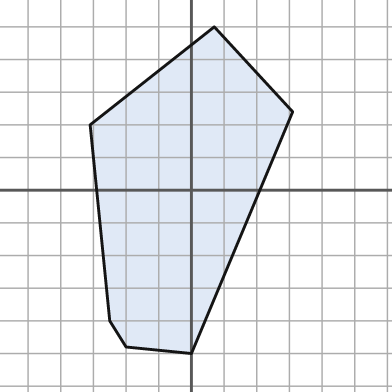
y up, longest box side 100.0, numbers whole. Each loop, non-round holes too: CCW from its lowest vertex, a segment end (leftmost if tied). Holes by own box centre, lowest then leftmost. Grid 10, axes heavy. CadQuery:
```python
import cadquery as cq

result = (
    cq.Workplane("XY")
    .moveTo(0.0, -50.0)
    .lineTo(31.0, 24.0)
    .lineTo(7.0, 50.0)
    .lineTo(-31.0, 20.0)
    .lineTo(-25.0, -40.0)
    .lineTo(-20.0, -48.0)
    .close()
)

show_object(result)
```